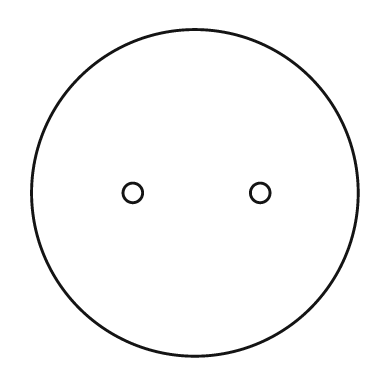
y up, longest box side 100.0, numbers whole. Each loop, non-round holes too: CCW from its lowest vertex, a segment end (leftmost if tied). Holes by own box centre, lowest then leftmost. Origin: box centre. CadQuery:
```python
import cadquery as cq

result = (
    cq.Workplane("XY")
    .moveTo(0.0, 0.0)
    .circle(50.0)
    .moveTo(-19.0, 0.0)
    .circle(3.0)
    .moveTo(20.0, 0.0)
    .circle(3.0)
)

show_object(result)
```